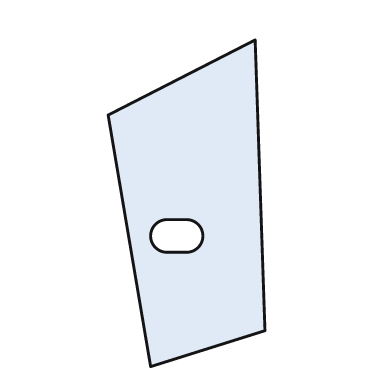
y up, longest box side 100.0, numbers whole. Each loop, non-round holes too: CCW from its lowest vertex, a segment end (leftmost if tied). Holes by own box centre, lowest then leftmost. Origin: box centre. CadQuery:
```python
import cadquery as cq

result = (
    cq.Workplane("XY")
    .moveTo(-11.0, -50.0)
    .lineTo(24.0, -39.0)
    .lineTo(21.0, 50.0)
    .lineTo(-24.0, 27.0)
    .close()
    .moveTo(-6.0, -15.0)
    .lineTo(0.0, -15.0)
    .threePointArc((5.0, -10.0), (0.0, -5.0))
    .lineTo(-6.0, -5.0)
    .threePointArc((-11.0, -10.0), (-6.0, -15.0))
    .close()
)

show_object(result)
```